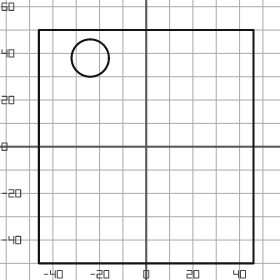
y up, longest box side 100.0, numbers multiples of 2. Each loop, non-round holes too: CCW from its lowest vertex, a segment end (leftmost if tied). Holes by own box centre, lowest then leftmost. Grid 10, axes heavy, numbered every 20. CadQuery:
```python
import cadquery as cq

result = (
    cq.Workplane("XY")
    .moveTo(-46.0, -50.0)
    .lineTo(46.0, -50.0)
    .lineTo(46.0, 50.0)
    .lineTo(-46.0, 50.0)
    .close()
    .moveTo(-24.0, 38.0)
    .circle(8.0)
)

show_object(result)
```